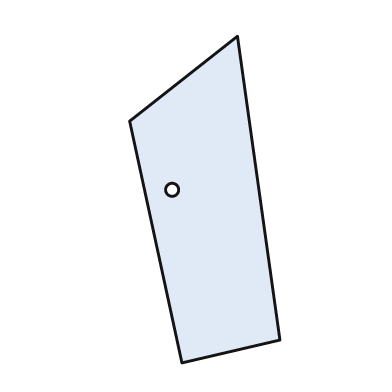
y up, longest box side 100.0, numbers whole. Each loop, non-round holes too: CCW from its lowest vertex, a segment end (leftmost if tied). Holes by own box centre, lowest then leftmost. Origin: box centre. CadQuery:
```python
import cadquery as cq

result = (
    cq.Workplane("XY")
    .moveTo(-7.0, -50.0)
    .lineTo(23.0, -43.0)
    .lineTo(10.0, 50.0)
    .lineTo(-23.0, 24.0)
    .close()
    .moveTo(-10.0, 3.0)
    .circle(2.0)
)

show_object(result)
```